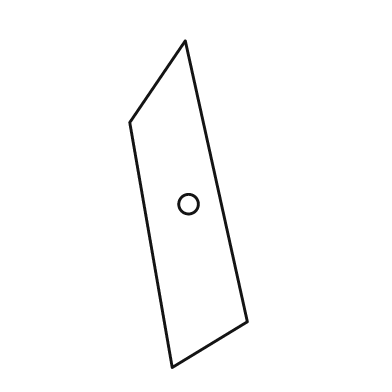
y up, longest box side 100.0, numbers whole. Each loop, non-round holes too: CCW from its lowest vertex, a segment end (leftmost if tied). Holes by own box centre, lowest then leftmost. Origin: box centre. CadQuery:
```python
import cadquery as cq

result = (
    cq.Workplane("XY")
    .moveTo(-5.0, -50.0)
    .lineTo(18.0, -36.0)
    .lineTo(-1.0, 50.0)
    .lineTo(-18.0, 25.0)
    .close()
    .moveTo(0.0, 0.0)
    .circle(3.0)
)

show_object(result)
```